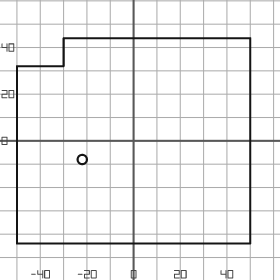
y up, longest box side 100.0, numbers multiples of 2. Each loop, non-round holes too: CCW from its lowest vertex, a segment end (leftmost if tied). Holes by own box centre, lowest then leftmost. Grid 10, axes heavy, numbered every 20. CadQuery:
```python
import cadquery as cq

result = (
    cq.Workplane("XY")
    .moveTo(-50.0, -44.0)
    .lineTo(50.0, -44.0)
    .lineTo(50.0, 44.0)
    .lineTo(-30.0, 44.0)
    .lineTo(-30.0, 32.0)
    .lineTo(-50.0, 32.0)
    .close()
    .moveTo(-22.0, -8.0)
    .circle(2.0)
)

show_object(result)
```